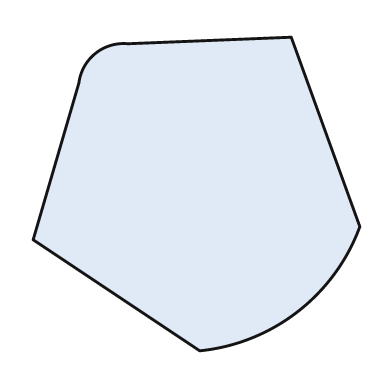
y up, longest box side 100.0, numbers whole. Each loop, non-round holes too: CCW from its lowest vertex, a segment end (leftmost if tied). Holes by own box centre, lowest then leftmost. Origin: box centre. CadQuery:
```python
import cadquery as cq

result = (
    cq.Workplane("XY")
    .moveTo(1.0, -48.0)
    .threePointArc((31.0, -36.0), (50.0, -10.0))
    .lineTo(29.0, 48.0)
    .lineTo(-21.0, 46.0)
    .threePointArc((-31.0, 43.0), (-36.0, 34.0))
    .lineTo(-50.0, -14.0)
    .close()
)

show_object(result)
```